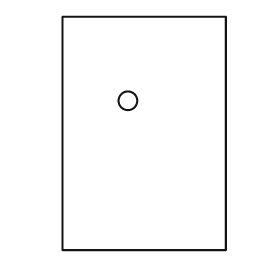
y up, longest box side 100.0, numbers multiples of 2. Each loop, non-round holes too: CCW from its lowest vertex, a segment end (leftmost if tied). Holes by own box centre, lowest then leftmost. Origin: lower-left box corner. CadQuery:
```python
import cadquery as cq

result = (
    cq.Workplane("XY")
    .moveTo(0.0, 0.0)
    .lineTo(70.0, 0.0)
    .lineTo(70.0, 100.0)
    .lineTo(0.0, 100.0)
    .close()
    .moveTo(28.0, 64.0)
    .circle(4.0)
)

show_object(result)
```